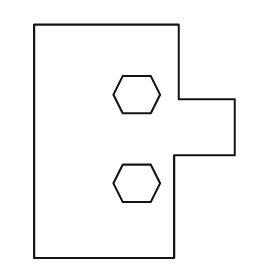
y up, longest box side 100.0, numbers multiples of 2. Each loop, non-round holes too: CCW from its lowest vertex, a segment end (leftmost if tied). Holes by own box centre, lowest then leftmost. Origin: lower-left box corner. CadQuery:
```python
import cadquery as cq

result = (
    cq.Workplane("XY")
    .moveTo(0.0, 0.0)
    .lineTo(60.0, 0.0)
    .lineTo(60.0, 44.0)
    .lineTo(86.0, 44.0)
    .lineTo(86.0, 68.0)
    .lineTo(62.0, 68.0)
    .lineTo(62.0, 100.0)
    .lineTo(0.0, 100.0)
    .close()
    .moveTo(38.0, 24.0)
    .lineTo(50.0, 24.0)
    .lineTo(54.0, 32.0)
    .lineTo(50.0, 40.0)
    .lineTo(38.0, 40.0)
    .lineTo(34.0, 32.0)
    .close()
    .moveTo(38.0, 62.0)
    .lineTo(50.0, 62.0)
    .lineTo(54.0, 70.0)
    .lineTo(50.0, 78.0)
    .lineTo(38.0, 78.0)
    .lineTo(34.0, 70.0)
    .close()
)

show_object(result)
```